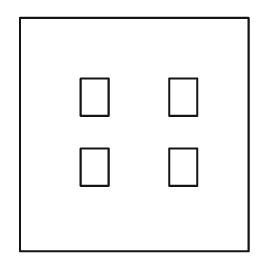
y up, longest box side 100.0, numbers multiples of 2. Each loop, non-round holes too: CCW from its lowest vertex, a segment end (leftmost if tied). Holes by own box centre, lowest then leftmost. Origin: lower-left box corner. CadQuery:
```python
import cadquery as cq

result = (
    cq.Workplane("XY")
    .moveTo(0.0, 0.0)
    .lineTo(98.0, 0.0)
    .lineTo(98.0, 100.0)
    .lineTo(0.0, 100.0)
    .close()
    .moveTo(26.0, 28.0)
    .lineTo(38.0, 28.0)
    .lineTo(38.0, 44.0)
    .lineTo(26.0, 44.0)
    .close()
    .moveTo(64.0, 28.0)
    .lineTo(76.0, 28.0)
    .lineTo(76.0, 44.0)
    .lineTo(64.0, 44.0)
    .close()
    .moveTo(26.0, 58.0)
    .lineTo(38.0, 58.0)
    .lineTo(38.0, 74.0)
    .lineTo(26.0, 74.0)
    .close()
    .moveTo(64.0, 58.0)
    .lineTo(76.0, 58.0)
    .lineTo(76.0, 74.0)
    .lineTo(64.0, 74.0)
    .close()
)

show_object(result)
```